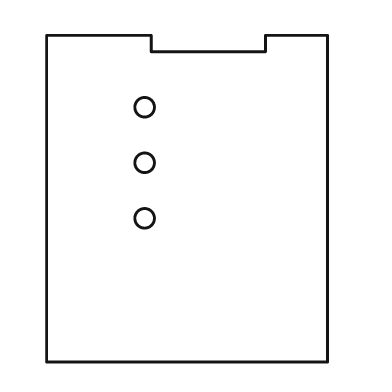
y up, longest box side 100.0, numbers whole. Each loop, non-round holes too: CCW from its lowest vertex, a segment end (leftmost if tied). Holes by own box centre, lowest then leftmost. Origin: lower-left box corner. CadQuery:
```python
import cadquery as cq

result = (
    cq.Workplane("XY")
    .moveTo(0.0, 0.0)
    .lineTo(86.0, 0.0)
    .lineTo(86.0, 100.0)
    .lineTo(67.0, 100.0)
    .lineTo(67.0, 95.0)
    .lineTo(32.0, 95.0)
    .lineTo(32.0, 100.0)
    .lineTo(0.0, 100.0)
    .close()
    .moveTo(30.0, 44.0)
    .circle(3.0)
    .moveTo(30.0, 61.0)
    .circle(3.0)
    .moveTo(30.0, 78.0)
    .circle(3.0)
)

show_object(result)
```